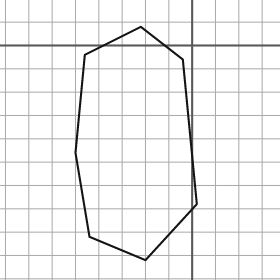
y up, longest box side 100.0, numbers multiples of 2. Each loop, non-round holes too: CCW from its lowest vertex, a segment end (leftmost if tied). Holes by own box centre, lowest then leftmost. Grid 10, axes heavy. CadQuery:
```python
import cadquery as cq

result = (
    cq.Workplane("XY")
    .moveTo(-20.0, -92.0)
    .lineTo(2.0, -68.0)
    .lineTo(-4.0, -6.0)
    .lineTo(-22.0, 8.0)
    .lineTo(-46.0, -4.0)
    .lineTo(-50.0, -46.0)
    .lineTo(-44.0, -82.0)
    .close()
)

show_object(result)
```